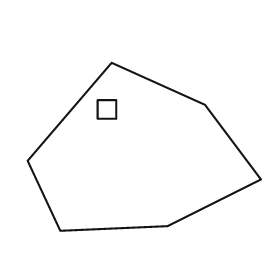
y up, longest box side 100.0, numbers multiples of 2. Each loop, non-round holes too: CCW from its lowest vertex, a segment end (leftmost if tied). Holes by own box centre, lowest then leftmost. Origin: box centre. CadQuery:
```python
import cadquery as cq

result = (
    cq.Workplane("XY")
    .moveTo(-36.0, -36.0)
    .lineTo(10.0, -34.0)
    .lineTo(50.0, -14.0)
    .lineTo(26.0, 18.0)
    .lineTo(-14.0, 36.0)
    .lineTo(-50.0, -6.0)
    .close()
    .moveTo(-20.0, 12.0)
    .lineTo(-12.0, 12.0)
    .lineTo(-12.0, 20.0)
    .lineTo(-20.0, 20.0)
    .close()
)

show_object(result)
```